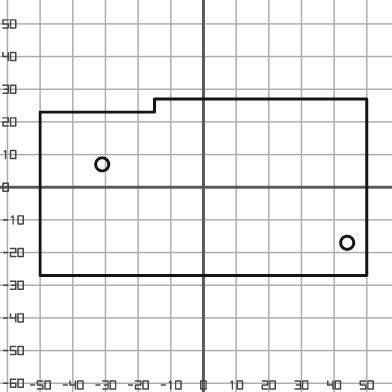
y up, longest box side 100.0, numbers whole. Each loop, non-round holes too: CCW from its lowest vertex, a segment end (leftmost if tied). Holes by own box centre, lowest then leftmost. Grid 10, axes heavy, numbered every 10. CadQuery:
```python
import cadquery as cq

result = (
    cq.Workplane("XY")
    .moveTo(-50.0, -27.0)
    .lineTo(50.0, -27.0)
    .lineTo(50.0, 27.0)
    .lineTo(-15.0, 27.0)
    .lineTo(-15.0, 23.0)
    .lineTo(-50.0, 23.0)
    .close()
    .moveTo(44.0, -17.0)
    .circle(2.0)
    .moveTo(-31.0, 7.0)
    .circle(2.0)
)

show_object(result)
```